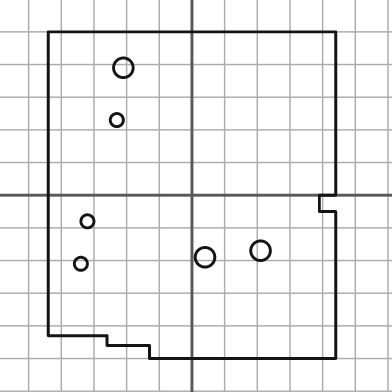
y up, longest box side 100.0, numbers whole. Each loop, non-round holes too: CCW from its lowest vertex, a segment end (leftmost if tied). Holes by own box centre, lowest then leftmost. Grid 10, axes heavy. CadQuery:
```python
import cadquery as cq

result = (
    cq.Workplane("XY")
    .moveTo(-13.0, -50.0)
    .lineTo(44.0, -50.0)
    .lineTo(44.0, -5.0)
    .lineTo(39.0, -5.0)
    .lineTo(39.0, 0.0)
    .lineTo(44.0, 0.0)
    .lineTo(44.0, 50.0)
    .lineTo(-44.0, 50.0)
    .lineTo(-44.0, -43.0)
    .lineTo(-26.0, -43.0)
    .lineTo(-26.0, -46.0)
    .lineTo(-13.0, -46.0)
    .close()
    .moveTo(-34.0, -21.0)
    .circle(2.0)
    .moveTo(4.0, -19.0)
    .circle(3.0)
    .moveTo(21.0, -17.0)
    .circle(3.0)
    .moveTo(-32.0, -8.0)
    .circle(2.0)
    .moveTo(-23.0, 23.0)
    .circle(2.0)
    .moveTo(-21.0, 39.0)
    .circle(3.0)
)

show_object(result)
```